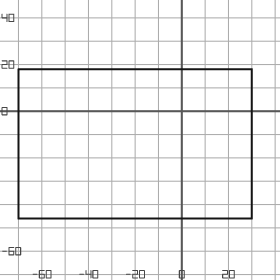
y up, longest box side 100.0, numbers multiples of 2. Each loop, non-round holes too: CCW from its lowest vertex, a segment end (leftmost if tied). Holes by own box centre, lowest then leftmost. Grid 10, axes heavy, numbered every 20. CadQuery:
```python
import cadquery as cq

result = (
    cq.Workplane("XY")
    .moveTo(-70.0, -46.0)
    .lineTo(30.0, -46.0)
    .lineTo(30.0, 18.0)
    .lineTo(-70.0, 18.0)
    .close()
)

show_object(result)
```